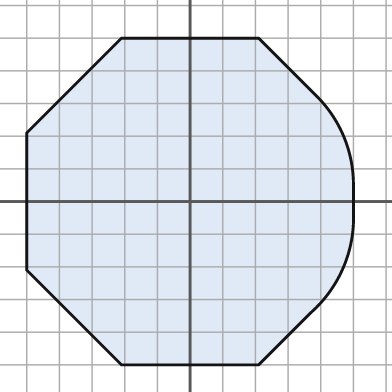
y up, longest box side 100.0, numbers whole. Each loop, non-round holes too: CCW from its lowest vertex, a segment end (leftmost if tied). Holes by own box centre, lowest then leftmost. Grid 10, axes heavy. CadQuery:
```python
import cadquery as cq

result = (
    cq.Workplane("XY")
    .moveTo(-21.0, -50.0)
    .lineTo(21.0, -50.0)
    .lineTo(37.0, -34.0)
    .threePointArc((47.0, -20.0), (50.0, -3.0))
    .lineTo(50.0, 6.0)
    .threePointArc((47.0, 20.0), (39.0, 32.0))
    .lineTo(21.0, 50.0)
    .lineTo(-21.0, 50.0)
    .lineTo(-50.0, 21.0)
    .lineTo(-50.0, -21.0)
    .close()
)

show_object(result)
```